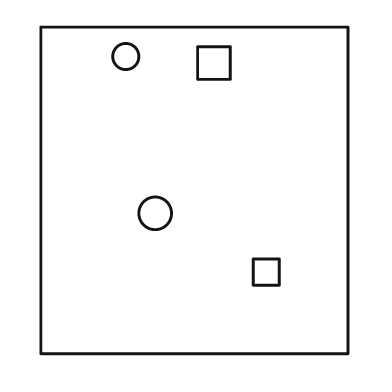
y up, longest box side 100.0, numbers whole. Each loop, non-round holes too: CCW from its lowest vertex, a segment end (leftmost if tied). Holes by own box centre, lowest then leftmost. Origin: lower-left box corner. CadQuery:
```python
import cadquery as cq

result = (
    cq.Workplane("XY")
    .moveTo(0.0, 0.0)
    .lineTo(94.0, 0.0)
    .lineTo(94.0, 100.0)
    .lineTo(0.0, 100.0)
    .close()
    .moveTo(65.0, 21.0)
    .lineTo(73.0, 21.0)
    .lineTo(73.0, 29.0)
    .lineTo(65.0, 29.0)
    .close()
    .moveTo(35.0, 43.0)
    .circle(5.0)
    .moveTo(48.0, 84.0)
    .lineTo(58.0, 84.0)
    .lineTo(58.0, 94.0)
    .lineTo(48.0, 94.0)
    .close()
    .moveTo(26.0, 91.0)
    .circle(4.0)
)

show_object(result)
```